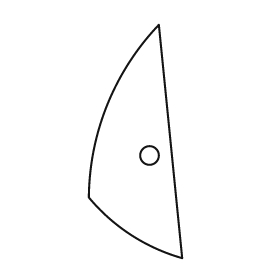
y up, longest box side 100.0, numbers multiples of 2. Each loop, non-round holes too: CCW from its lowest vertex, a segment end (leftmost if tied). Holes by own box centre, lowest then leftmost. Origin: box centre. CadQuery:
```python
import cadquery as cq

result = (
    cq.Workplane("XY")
    .moveTo(20.0, -50.0)
    .lineTo(10.0, 50.0)
    .threePointArc((-12.0, 16.0), (-20.0, -24.0))
    .threePointArc((-2.0, -40.0), (20.0, -50.0))
    .close()
    .moveTo(6.0, -6.0)
    .circle(4.0)
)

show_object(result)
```